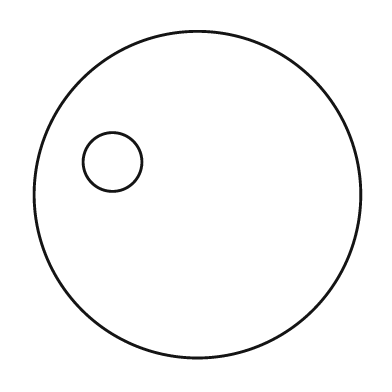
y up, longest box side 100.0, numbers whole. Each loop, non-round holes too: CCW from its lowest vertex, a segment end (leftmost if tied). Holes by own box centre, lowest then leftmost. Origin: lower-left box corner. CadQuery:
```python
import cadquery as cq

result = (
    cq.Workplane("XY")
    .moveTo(50.0, 50.0)
    .circle(50.0)
    .moveTo(24.0, 60.0)
    .circle(9.0)
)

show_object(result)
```